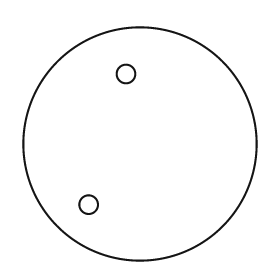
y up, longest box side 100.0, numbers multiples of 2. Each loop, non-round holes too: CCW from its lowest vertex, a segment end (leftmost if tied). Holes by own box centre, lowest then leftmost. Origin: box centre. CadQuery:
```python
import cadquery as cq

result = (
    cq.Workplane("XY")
    .moveTo(0.0, 0.0)
    .circle(50.0)
    .moveTo(-22.0, -26.0)
    .circle(4.0)
    .moveTo(-6.0, 30.0)
    .circle(4.0)
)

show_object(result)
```